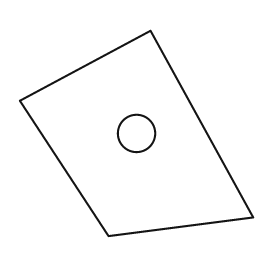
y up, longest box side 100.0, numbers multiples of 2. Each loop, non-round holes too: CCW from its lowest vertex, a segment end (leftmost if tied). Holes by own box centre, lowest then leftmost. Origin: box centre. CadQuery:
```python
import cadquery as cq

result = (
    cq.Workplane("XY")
    .moveTo(-12.0, -44.0)
    .lineTo(50.0, -36.0)
    .lineTo(6.0, 44.0)
    .lineTo(-50.0, 14.0)
    .close()
    .moveTo(0.0, 0.0)
    .circle(8.0)
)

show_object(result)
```